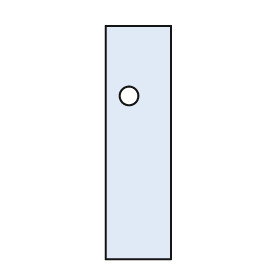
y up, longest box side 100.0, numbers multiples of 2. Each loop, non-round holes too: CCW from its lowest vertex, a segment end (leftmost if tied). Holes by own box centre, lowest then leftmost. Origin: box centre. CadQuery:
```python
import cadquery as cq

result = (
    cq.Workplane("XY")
    .moveTo(-14.0, -50.0)
    .lineTo(14.0, -50.0)
    .lineTo(14.0, 50.0)
    .lineTo(-14.0, 50.0)
    .close()
    .moveTo(-4.0, 20.0)
    .circle(4.0)
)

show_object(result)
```